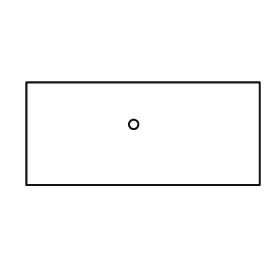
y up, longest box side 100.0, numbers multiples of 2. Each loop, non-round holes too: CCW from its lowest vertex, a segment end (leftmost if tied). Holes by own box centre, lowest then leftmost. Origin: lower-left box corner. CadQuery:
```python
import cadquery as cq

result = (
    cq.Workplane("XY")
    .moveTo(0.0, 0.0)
    .lineTo(100.0, 0.0)
    .lineTo(100.0, 44.0)
    .lineTo(0.0, 44.0)
    .close()
    .moveTo(46.0, 26.0)
    .circle(2.0)
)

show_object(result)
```